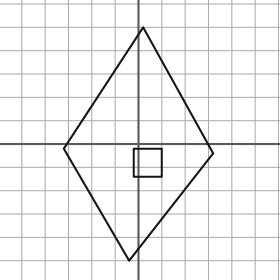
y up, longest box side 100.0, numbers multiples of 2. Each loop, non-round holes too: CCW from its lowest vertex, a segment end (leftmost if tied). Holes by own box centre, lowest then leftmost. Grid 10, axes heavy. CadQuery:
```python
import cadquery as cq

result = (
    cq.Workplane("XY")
    .moveTo(-4.0, -50.0)
    .lineTo(32.0, -4.0)
    .lineTo(2.0, 50.0)
    .lineTo(-32.0, -2.0)
    .close()
    .moveTo(-2.0, -14.0)
    .lineTo(10.0, -14.0)
    .lineTo(10.0, -2.0)
    .lineTo(-2.0, -2.0)
    .close()
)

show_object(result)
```